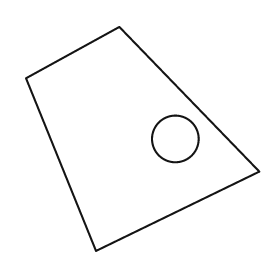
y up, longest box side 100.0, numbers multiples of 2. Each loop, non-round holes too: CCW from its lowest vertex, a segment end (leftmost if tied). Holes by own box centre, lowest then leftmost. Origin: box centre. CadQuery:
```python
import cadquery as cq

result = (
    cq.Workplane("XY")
    .moveTo(-20.0, -48.0)
    .lineTo(50.0, -14.0)
    .lineTo(-10.0, 48.0)
    .lineTo(-50.0, 26.0)
    .close()
    .moveTo(14.0, 0.0)
    .circle(10.0)
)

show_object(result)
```